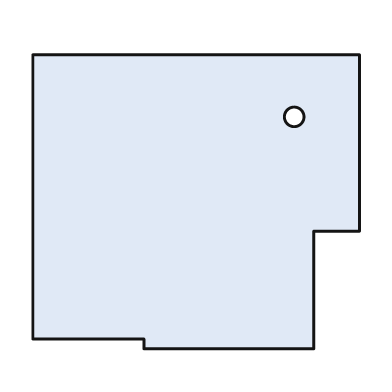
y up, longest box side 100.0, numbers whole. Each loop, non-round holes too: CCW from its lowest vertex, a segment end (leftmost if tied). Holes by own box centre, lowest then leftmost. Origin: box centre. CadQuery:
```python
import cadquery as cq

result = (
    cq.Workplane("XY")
    .moveTo(-16.0, -45.0)
    .lineTo(36.0, -45.0)
    .lineTo(36.0, -9.0)
    .lineTo(50.0, -9.0)
    .lineTo(50.0, 45.0)
    .lineTo(-50.0, 45.0)
    .lineTo(-50.0, -42.0)
    .lineTo(-16.0, -42.0)
    .close()
    .moveTo(30.0, 26.0)
    .circle(3.0)
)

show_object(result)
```